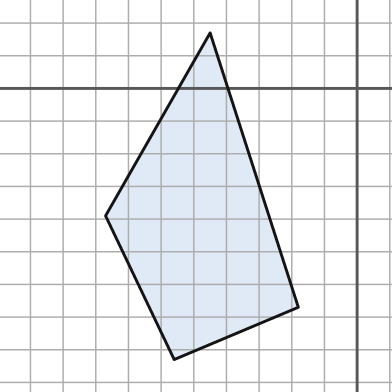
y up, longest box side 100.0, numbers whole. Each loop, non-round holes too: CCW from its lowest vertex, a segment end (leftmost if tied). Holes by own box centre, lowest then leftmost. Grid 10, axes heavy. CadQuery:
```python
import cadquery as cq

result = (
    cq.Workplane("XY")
    .moveTo(-56.0, -83.0)
    .lineTo(-18.0, -67.0)
    .lineTo(-45.0, 17.0)
    .lineTo(-77.0, -39.0)
    .close()
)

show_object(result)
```